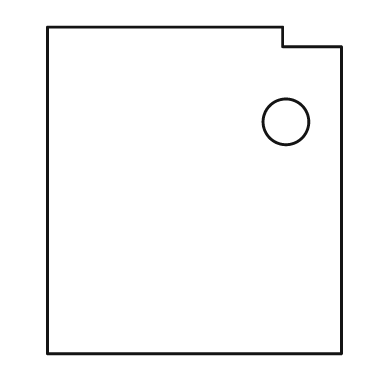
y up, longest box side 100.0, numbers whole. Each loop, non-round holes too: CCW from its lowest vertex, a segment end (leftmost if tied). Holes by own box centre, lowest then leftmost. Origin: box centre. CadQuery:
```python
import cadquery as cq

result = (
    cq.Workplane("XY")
    .moveTo(-45.0, -50.0)
    .lineTo(45.0, -50.0)
    .lineTo(45.0, 44.0)
    .lineTo(27.0, 44.0)
    .lineTo(27.0, 50.0)
    .lineTo(-45.0, 50.0)
    .close()
    .moveTo(28.0, 21.0)
    .circle(7.0)
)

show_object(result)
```